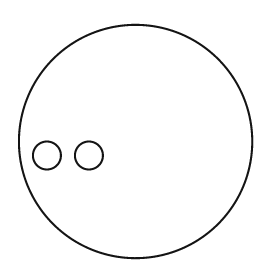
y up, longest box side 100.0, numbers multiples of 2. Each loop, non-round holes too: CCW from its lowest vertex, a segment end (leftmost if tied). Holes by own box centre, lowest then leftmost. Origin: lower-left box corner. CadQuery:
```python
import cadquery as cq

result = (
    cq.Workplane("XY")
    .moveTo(50.0, 50.0)
    .circle(50.0)
    .moveTo(12.0, 44.0)
    .circle(6.0)
    .moveTo(30.0, 44.0)
    .circle(6.0)
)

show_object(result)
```